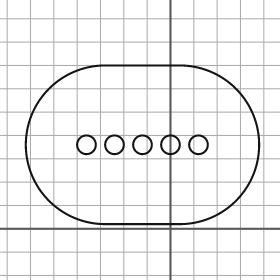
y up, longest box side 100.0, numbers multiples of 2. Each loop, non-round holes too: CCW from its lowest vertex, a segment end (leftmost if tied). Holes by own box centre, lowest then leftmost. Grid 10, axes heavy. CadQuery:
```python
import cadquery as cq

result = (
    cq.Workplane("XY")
    .moveTo(-28.0, 2.0)
    .lineTo(4.0, 2.0)
    .threePointArc((38.0, 36.0), (4.0, 70.0))
    .lineTo(-28.0, 70.0)
    .threePointArc((-62.0, 36.0), (-28.0, 2.0))
    .close()
    .moveTo(-36.0, 36.0)
    .circle(4.0)
    .moveTo(-24.0, 36.0)
    .circle(4.0)
    .moveTo(-12.0, 36.0)
    .circle(4.0)
    .moveTo(0.0, 36.0)
    .circle(4.0)
    .moveTo(12.0, 36.0)
    .circle(4.0)
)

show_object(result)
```